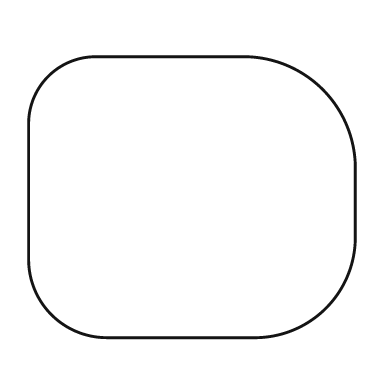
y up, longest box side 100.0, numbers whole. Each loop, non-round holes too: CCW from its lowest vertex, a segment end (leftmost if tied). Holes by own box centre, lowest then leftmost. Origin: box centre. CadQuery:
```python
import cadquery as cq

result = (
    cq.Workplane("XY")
    .moveTo(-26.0, -43.0)
    .lineTo(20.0, -43.0)
    .threePointArc((41.0, -34.0), (50.0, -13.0))
    .lineTo(50.0, 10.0)
    .threePointArc((40.0, 33.0), (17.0, 43.0))
    .lineTo(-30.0, 43.0)
    .threePointArc((-44.0, 37.0), (-50.0, 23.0))
    .lineTo(-50.0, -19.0)
    .threePointArc((-43.0, -36.0), (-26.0, -43.0))
    .close()
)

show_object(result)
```